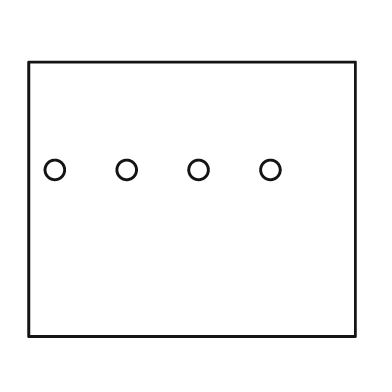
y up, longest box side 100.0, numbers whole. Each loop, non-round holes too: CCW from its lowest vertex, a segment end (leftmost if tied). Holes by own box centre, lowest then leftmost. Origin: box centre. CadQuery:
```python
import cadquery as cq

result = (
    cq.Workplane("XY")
    .moveTo(-50.0, -42.0)
    .lineTo(50.0, -42.0)
    .lineTo(50.0, 42.0)
    .lineTo(-50.0, 42.0)
    .close()
    .moveTo(-42.0, 9.0)
    .circle(3.0)
    .moveTo(-20.0, 9.0)
    .circle(3.0)
    .moveTo(2.0, 9.0)
    .circle(3.0)
    .moveTo(24.0, 9.0)
    .circle(3.0)
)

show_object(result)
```